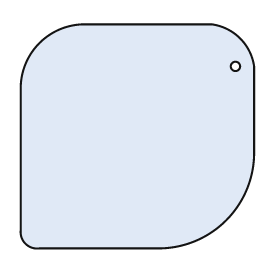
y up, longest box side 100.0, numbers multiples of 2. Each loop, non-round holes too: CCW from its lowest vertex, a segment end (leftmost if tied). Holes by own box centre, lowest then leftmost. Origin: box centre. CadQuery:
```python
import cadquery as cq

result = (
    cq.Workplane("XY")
    .moveTo(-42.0, -48.0)
    .lineTo(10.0, -48.0)
    .threePointArc((38.0, -36.0), (50.0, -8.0))
    .lineTo(50.0, 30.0)
    .threePointArc((44.0, 42.0), (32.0, 48.0))
    .lineTo(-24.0, 48.0)
    .threePointArc((-42.0, 40.0), (-50.0, 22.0))
    .lineTo(-50.0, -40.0)
    .threePointArc((-48.0, -46.0), (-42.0, -48.0))
    .close()
    .moveTo(42.0, 30.0)
    .circle(2.0)
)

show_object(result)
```